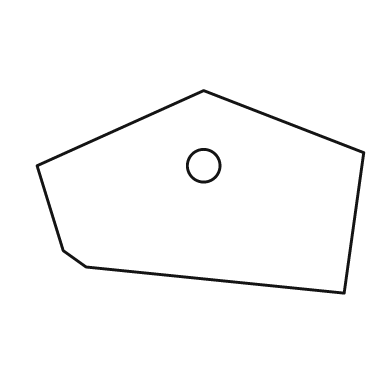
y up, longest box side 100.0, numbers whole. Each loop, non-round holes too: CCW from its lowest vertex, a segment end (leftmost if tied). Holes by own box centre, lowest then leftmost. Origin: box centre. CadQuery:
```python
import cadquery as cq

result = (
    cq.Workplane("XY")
    .moveTo(44.0, -31.0)
    .lineTo(50.0, 12.0)
    .lineTo(1.0, 31.0)
    .lineTo(-50.0, 8.0)
    .lineTo(-42.0, -18.0)
    .lineTo(-35.0, -23.0)
    .close()
    .moveTo(1.0, 8.0)
    .circle(5.0)
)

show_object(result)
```